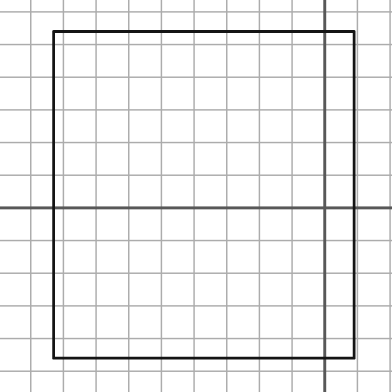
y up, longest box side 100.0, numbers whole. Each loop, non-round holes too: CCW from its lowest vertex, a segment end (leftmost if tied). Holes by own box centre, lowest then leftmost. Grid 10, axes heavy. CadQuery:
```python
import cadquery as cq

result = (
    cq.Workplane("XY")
    .moveTo(-83.0, -46.0)
    .lineTo(9.0, -46.0)
    .lineTo(9.0, 54.0)
    .lineTo(-83.0, 54.0)
    .close()
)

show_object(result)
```